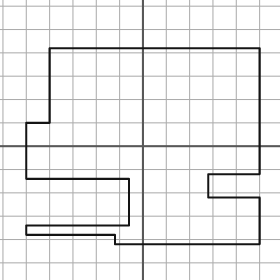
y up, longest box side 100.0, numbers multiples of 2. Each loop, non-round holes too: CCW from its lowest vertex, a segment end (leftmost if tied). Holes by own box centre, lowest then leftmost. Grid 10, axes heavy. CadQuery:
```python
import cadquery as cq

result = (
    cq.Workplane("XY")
    .moveTo(-12.0, -42.0)
    .lineTo(50.0, -42.0)
    .lineTo(50.0, -22.0)
    .lineTo(28.0, -22.0)
    .lineTo(28.0, -12.0)
    .lineTo(50.0, -12.0)
    .lineTo(50.0, 42.0)
    .lineTo(-40.0, 42.0)
    .lineTo(-40.0, 10.0)
    .lineTo(-50.0, 10.0)
    .lineTo(-50.0, -14.0)
    .lineTo(-6.0, -14.0)
    .lineTo(-6.0, -34.0)
    .lineTo(-50.0, -34.0)
    .lineTo(-50.0, -38.0)
    .lineTo(-12.0, -38.0)
    .close()
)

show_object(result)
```